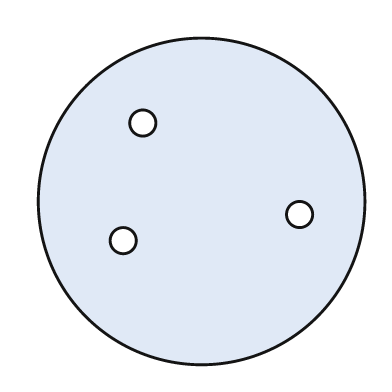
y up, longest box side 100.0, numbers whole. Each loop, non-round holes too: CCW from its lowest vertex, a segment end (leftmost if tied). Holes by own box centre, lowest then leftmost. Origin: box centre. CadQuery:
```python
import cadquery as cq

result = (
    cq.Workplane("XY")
    .moveTo(0.0, 0.0)
    .circle(50.0)
    .moveTo(-24.0, -12.0)
    .circle(4.0)
    .moveTo(30.0, -4.0)
    .circle(4.0)
    .moveTo(-18.0, 24.0)
    .circle(4.0)
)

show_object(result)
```